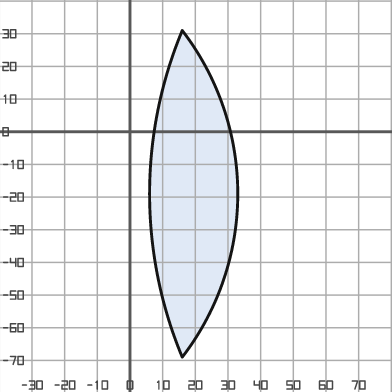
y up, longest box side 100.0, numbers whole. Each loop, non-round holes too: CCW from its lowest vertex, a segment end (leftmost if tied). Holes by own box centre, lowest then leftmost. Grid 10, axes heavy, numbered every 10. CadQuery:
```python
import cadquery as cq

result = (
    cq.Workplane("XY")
    .moveTo(16.0, -69.0)
    .threePointArc((33.0, -19.0), (16.0, 31.0))
    .threePointArc((6.0, -19.0), (16.0, -69.0))
    .close()
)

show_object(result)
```